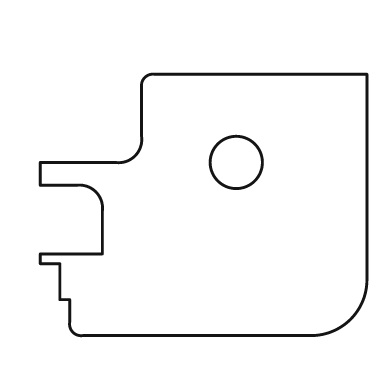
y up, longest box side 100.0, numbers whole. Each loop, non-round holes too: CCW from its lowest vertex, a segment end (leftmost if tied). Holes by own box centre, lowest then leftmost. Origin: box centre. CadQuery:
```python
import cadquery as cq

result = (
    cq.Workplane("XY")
    .moveTo(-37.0, -40.0)
    .lineTo(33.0, -40.0)
    .threePointArc((45.0, -35.0), (50.0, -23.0))
    .lineTo(50.0, 40.0)
    .lineTo(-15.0, 40.0)
    .threePointArc((-18.0, 39.0), (-19.0, 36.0))
    .lineTo(-19.0, 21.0)
    .threePointArc((-21.0, 15.0), (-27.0, 13.0))
    .lineTo(-50.0, 13.0)
    .lineTo(-50.0, 6.0)
    .lineTo(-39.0, 6.0)
    .threePointArc((-33.0, 4.0), (-31.0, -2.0))
    .lineTo(-31.0, -15.0)
    .lineTo(-50.0, -15.0)
    .lineTo(-50.0, -18.0)
    .lineTo(-44.0, -18.0)
    .lineTo(-44.0, -29.0)
    .lineTo(-41.0, -29.0)
    .lineTo(-41.0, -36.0)
    .threePointArc((-40.0, -39.0), (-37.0, -40.0))
    .close()
    .moveTo(10.0, 13.0)
    .circle(8.0)
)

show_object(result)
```